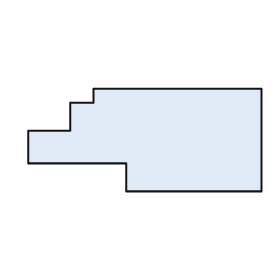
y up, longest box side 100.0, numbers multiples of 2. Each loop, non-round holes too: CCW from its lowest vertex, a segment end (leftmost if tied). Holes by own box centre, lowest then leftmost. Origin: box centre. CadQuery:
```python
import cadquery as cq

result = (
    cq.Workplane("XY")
    .moveTo(-8.0, -22.0)
    .lineTo(50.0, -22.0)
    .lineTo(50.0, 22.0)
    .lineTo(-22.0, 22.0)
    .lineTo(-22.0, 16.0)
    .lineTo(-32.0, 16.0)
    .lineTo(-32.0, 4.0)
    .lineTo(-50.0, 4.0)
    .lineTo(-50.0, -10.0)
    .lineTo(-8.0, -10.0)
    .close()
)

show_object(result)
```